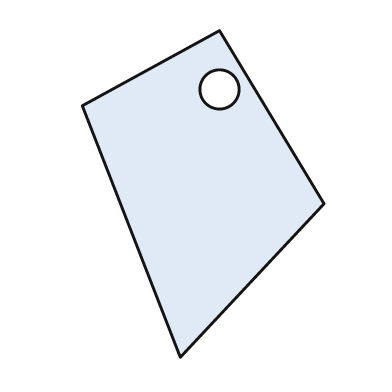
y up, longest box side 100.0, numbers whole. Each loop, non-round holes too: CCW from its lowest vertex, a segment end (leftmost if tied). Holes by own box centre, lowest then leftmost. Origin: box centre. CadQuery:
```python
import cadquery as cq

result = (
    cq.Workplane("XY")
    .moveTo(-7.0, -50.0)
    .lineTo(37.0, -3.0)
    .lineTo(5.0, 50.0)
    .lineTo(-37.0, 27.0)
    .close()
    .moveTo(5.0, 32.0)
    .circle(6.0)
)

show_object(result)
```